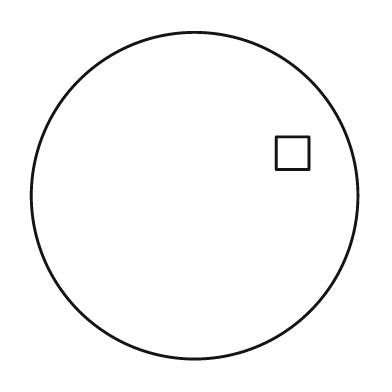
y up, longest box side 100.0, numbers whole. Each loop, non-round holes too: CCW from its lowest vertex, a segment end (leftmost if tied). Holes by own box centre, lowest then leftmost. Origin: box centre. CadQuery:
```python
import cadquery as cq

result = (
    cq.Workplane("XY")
    .moveTo(0.0, 0.0)
    .circle(50.0)
    .moveTo(25.0, 8.0)
    .lineTo(35.0, 8.0)
    .lineTo(35.0, 18.0)
    .lineTo(25.0, 18.0)
    .close()
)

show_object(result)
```